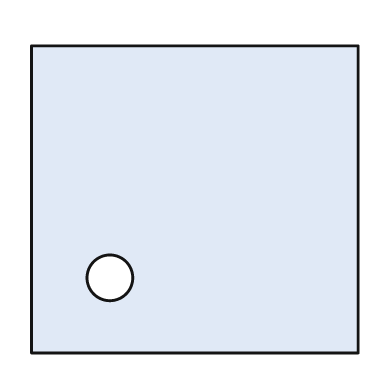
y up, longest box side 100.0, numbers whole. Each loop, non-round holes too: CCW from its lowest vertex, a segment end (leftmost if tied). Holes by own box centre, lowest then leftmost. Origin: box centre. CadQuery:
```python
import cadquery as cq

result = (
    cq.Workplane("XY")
    .moveTo(-50.0, -47.0)
    .lineTo(50.0, -47.0)
    .lineTo(50.0, 47.0)
    .lineTo(-50.0, 47.0)
    .close()
    .moveTo(-26.0, -24.0)
    .circle(7.0)
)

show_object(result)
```